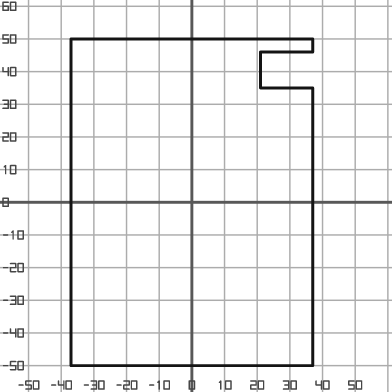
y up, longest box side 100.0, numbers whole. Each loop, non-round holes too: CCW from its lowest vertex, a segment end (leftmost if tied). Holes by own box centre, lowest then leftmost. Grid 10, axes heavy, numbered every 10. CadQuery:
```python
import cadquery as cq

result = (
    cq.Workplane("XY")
    .moveTo(-37.0, -50.0)
    .lineTo(37.0, -50.0)
    .lineTo(37.0, 35.0)
    .lineTo(21.0, 35.0)
    .lineTo(21.0, 46.0)
    .lineTo(37.0, 46.0)
    .lineTo(37.0, 50.0)
    .lineTo(-37.0, 50.0)
    .close()
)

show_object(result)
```